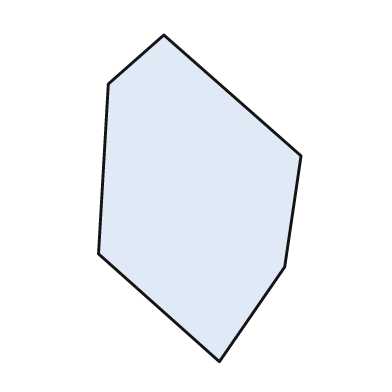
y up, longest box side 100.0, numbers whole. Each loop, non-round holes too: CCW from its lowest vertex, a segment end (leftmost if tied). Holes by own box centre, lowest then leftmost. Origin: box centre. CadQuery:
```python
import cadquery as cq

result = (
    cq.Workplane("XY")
    .moveTo(6.0, -50.0)
    .lineTo(26.0, -21.0)
    .lineTo(31.0, 13.0)
    .lineTo(-11.0, 50.0)
    .lineTo(-28.0, 35.0)
    .lineTo(-31.0, -17.0)
    .close()
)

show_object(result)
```